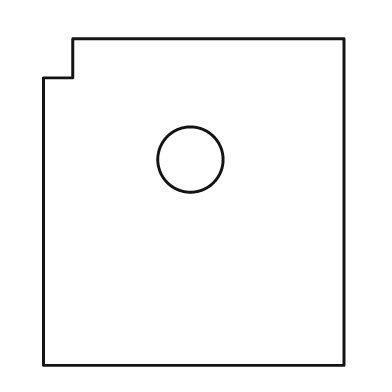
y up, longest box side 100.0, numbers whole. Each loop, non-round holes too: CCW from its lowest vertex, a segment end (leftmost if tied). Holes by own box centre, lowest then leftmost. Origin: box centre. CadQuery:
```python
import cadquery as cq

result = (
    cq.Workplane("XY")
    .moveTo(-46.0, -50.0)
    .lineTo(46.0, -50.0)
    .lineTo(46.0, 50.0)
    .lineTo(-37.0, 50.0)
    .lineTo(-37.0, 38.0)
    .lineTo(-46.0, 38.0)
    .close()
    .moveTo(-1.0, 13.0)
    .circle(10.0)
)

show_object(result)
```